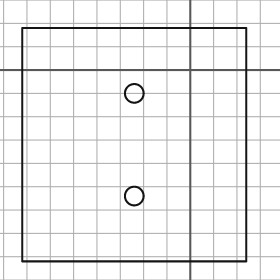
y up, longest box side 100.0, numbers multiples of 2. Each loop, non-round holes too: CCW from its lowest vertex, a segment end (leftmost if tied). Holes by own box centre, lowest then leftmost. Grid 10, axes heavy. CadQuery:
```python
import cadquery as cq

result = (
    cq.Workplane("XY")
    .moveTo(-72.0, -82.0)
    .lineTo(24.0, -82.0)
    .lineTo(24.0, 18.0)
    .lineTo(-72.0, 18.0)
    .close()
    .moveTo(-24.0, -54.0)
    .circle(4.0)
    .moveTo(-24.0, -10.0)
    .circle(4.0)
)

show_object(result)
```